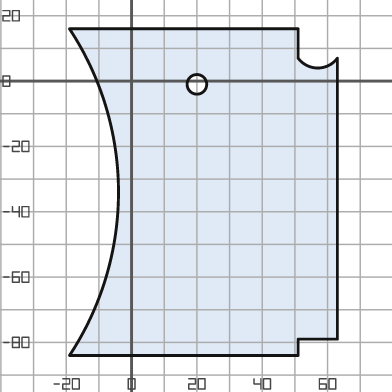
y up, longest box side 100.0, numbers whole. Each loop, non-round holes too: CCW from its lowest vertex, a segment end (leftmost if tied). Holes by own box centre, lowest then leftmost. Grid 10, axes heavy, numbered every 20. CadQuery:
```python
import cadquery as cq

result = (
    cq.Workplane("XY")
    .moveTo(-19.0, -84.0)
    .lineTo(51.0, -84.0)
    .lineTo(51.0, -79.0)
    .lineTo(63.0, -79.0)
    .lineTo(63.0, 7.0)
    .threePointArc((57.0, 4.0), (51.0, 7.0))
    .lineTo(51.0, 16.0)
    .lineTo(-19.0, 16.0)
    .threePointArc((-4.0, -34.0), (-19.0, -84.0))
    .close()
    .moveTo(20.0, -1.0)
    .circle(3.0)
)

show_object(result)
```